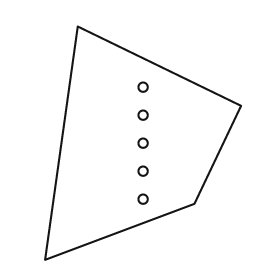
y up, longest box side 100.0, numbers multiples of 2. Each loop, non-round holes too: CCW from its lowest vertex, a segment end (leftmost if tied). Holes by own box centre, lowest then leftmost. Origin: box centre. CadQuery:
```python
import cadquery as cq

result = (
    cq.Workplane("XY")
    .moveTo(-42.0, -50.0)
    .lineTo(22.0, -26.0)
    .lineTo(42.0, 16.0)
    .lineTo(-28.0, 50.0)
    .close()
    .moveTo(0.0, -24.0)
    .circle(2.0)
    .moveTo(0.0, -12.0)
    .circle(2.0)
    .moveTo(0.0, 0.0)
    .circle(2.0)
    .moveTo(0.0, 12.0)
    .circle(2.0)
    .moveTo(0.0, 24.0)
    .circle(2.0)
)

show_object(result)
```